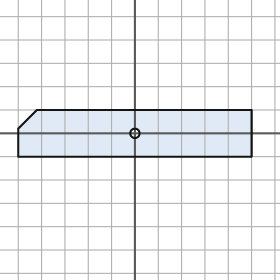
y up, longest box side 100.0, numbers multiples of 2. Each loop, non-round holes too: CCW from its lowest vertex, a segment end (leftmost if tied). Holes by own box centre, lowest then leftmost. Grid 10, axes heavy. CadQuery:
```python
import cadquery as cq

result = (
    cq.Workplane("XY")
    .moveTo(-50.0, -10.0)
    .lineTo(50.0, -10.0)
    .lineTo(50.0, 10.0)
    .lineTo(-42.0, 10.0)
    .lineTo(-50.0, 2.0)
    .close()
    .moveTo(0.0, 0.0)
    .circle(2.0)
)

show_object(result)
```